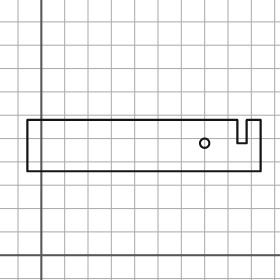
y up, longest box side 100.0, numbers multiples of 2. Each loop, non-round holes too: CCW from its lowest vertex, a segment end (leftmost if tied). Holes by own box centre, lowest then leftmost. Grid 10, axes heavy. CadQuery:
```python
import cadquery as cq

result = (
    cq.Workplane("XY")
    .moveTo(-6.0, 36.0)
    .lineTo(94.0, 36.0)
    .lineTo(94.0, 58.0)
    .lineTo(88.0, 58.0)
    .lineTo(88.0, 48.0)
    .lineTo(84.0, 48.0)
    .lineTo(84.0, 58.0)
    .lineTo(-6.0, 58.0)
    .close()
    .moveTo(70.0, 48.0)
    .circle(2.0)
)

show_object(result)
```